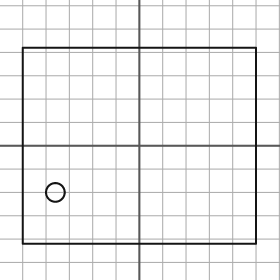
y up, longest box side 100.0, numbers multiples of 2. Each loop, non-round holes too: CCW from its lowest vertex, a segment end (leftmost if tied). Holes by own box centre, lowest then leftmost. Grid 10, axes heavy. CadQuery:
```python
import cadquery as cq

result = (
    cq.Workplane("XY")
    .moveTo(-50.0, -42.0)
    .lineTo(50.0, -42.0)
    .lineTo(50.0, 42.0)
    .lineTo(-50.0, 42.0)
    .close()
    .moveTo(-36.0, -20.0)
    .circle(4.0)
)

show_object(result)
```